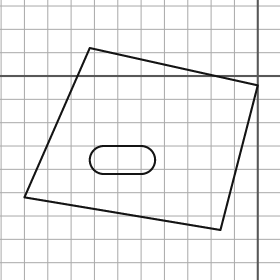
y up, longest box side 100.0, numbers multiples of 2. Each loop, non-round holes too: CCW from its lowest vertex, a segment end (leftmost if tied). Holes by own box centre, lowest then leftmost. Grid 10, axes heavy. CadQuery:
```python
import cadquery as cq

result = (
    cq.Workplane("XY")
    .moveTo(-16.0, -66.0)
    .lineTo(0.0, -4.0)
    .lineTo(-72.0, 12.0)
    .lineTo(-100.0, -52.0)
    .close()
    .moveTo(-66.0, -42.0)
    .lineTo(-50.0, -42.0)
    .threePointArc((-44.0, -36.0), (-50.0, -30.0))
    .lineTo(-66.0, -30.0)
    .threePointArc((-72.0, -36.0), (-66.0, -42.0))
    .close()
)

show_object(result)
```